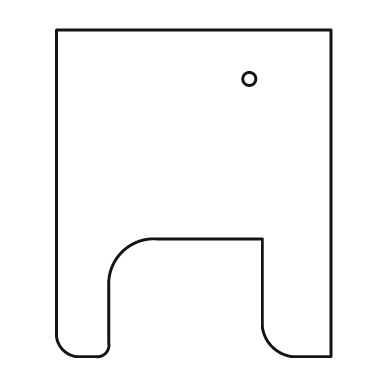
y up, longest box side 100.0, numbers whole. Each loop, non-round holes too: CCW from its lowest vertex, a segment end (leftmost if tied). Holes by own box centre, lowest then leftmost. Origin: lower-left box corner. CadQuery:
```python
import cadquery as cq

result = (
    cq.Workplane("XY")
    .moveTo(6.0, 0.0)
    .lineTo(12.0, 0.0)
    .threePointArc((15.0, 1.0), (16.0, 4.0))
    .lineTo(16.0, 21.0)
    .threePointArc((20.0, 32.0), (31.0, 36.0))
    .lineTo(63.0, 36.0)
    .lineTo(63.0, 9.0)
    .threePointArc((66.0, 3.0), (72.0, 0.0))
    .lineTo(84.0, 0.0)
    .lineTo(84.0, 100.0)
    .lineTo(0.0, 100.0)
    .lineTo(0.0, 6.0)
    .threePointArc((2.0, 2.0), (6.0, 0.0))
    .close()
    .moveTo(59.0, 85.0)
    .circle(2.0)
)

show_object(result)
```